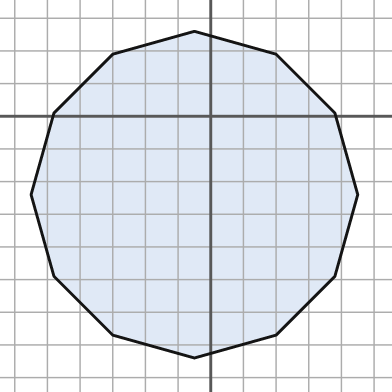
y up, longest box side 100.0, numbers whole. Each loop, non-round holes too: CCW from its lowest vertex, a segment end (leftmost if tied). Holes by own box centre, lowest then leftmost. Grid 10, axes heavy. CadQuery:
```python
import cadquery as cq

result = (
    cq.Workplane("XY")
    .moveTo(-5.0, -74.0)
    .lineTo(20.0, -67.0)
    .lineTo(38.0, -49.0)
    .lineTo(45.0, -24.0)
    .lineTo(38.0, 1.0)
    .lineTo(20.0, 19.0)
    .lineTo(-5.0, 26.0)
    .lineTo(-30.0, 19.0)
    .lineTo(-48.0, 1.0)
    .lineTo(-55.0, -24.0)
    .lineTo(-48.0, -49.0)
    .lineTo(-30.0, -67.0)
    .close()
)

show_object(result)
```